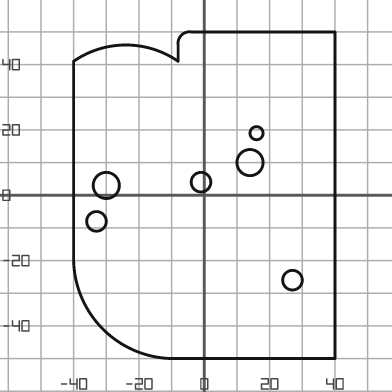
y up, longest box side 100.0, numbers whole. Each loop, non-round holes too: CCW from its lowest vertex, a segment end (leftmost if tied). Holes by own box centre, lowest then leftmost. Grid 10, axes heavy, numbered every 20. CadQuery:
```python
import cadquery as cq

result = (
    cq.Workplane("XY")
    .moveTo(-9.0, -50.0)
    .lineTo(40.0, -50.0)
    .lineTo(40.0, 50.0)
    .lineTo(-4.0, 50.0)
    .threePointArc((-7.0, 49.0), (-8.0, 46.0))
    .lineTo(-8.0, 41.0)
    .threePointArc((-24.0, 46.0), (-40.0, 41.0))
    .lineTo(-40.0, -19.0)
    .threePointArc((-31.0, -41.0), (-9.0, -50.0))
    .close()
    .moveTo(27.0, -26.0)
    .circle(3.0)
    .moveTo(-33.0, -8.0)
    .circle(3.0)
    .moveTo(-30.0, 3.0)
    .circle(4.0)
    .moveTo(-1.0, 4.0)
    .circle(3.0)
    .moveTo(14.0, 10.0)
    .circle(4.0)
    .moveTo(16.0, 19.0)
    .circle(2.0)
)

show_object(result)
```